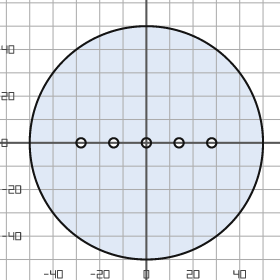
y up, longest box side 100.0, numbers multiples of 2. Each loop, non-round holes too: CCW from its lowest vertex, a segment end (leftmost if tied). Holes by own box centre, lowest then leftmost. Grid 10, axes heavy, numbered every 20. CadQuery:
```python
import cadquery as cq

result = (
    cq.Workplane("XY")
    .moveTo(0.0, 0.0)
    .circle(50.0)
    .moveTo(-28.0, 0.0)
    .circle(2.0)
    .moveTo(-14.0, 0.0)
    .circle(2.0)
    .moveTo(0.0, 0.0)
    .circle(2.0)
    .moveTo(14.0, 0.0)
    .circle(2.0)
    .moveTo(28.0, 0.0)
    .circle(2.0)
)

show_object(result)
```